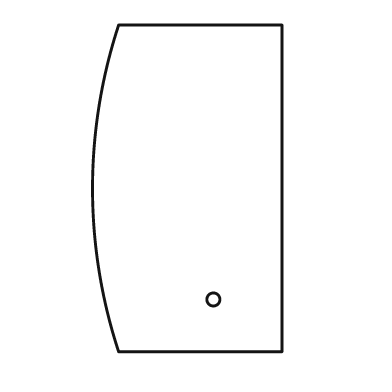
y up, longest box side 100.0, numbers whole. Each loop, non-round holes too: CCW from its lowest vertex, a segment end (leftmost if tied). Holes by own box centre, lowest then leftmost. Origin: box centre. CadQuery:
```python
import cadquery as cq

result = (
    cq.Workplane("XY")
    .moveTo(-21.0, -50.0)
    .lineTo(29.0, -50.0)
    .lineTo(29.0, 50.0)
    .lineTo(-21.0, 50.0)
    .threePointArc((-29.0, 0.0), (-21.0, -50.0))
    .close()
    .moveTo(8.0, -34.0)
    .circle(2.0)
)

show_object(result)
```